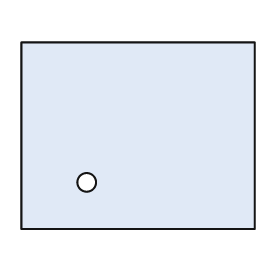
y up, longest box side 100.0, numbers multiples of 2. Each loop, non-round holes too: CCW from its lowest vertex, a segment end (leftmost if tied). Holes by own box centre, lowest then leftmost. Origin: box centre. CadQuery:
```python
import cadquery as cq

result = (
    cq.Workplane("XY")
    .moveTo(-50.0, -40.0)
    .lineTo(50.0, -40.0)
    .lineTo(50.0, 40.0)
    .lineTo(-50.0, 40.0)
    .close()
    .moveTo(-22.0, -20.0)
    .circle(4.0)
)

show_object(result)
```